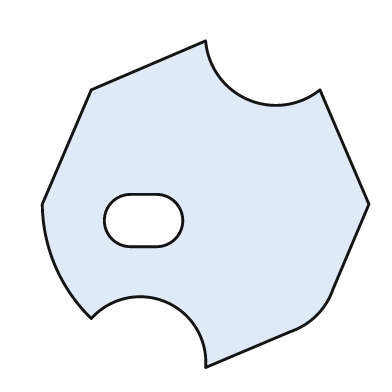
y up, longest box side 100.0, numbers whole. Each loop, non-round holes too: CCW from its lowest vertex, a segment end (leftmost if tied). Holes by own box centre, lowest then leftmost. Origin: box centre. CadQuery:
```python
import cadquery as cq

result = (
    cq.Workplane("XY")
    .moveTo(0.0, -50.0)
    .lineTo(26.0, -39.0)
    .threePointArc((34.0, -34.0), (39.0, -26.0))
    .lineTo(50.0, 0.0)
    .lineTo(35.0, 35.0)
    .threePointArc((13.0, 32.0), (0.0, 50.0))
    .lineTo(-35.0, 35.0)
    .lineTo(-50.0, 0.0)
    .threePointArc((-46.0, -19.0), (-35.0, -35.0))
    .threePointArc((-12.0, -30.0), (0.0, -50.0))
    .close()
    .moveTo(-23.0, -13.0)
    .lineTo(-15.0, -13.0)
    .threePointArc((-7.0, -5.0), (-15.0, 3.0))
    .lineTo(-23.0, 3.0)
    .threePointArc((-31.0, -5.0), (-23.0, -13.0))
    .close()
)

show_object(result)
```